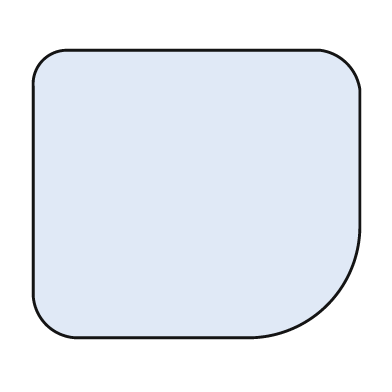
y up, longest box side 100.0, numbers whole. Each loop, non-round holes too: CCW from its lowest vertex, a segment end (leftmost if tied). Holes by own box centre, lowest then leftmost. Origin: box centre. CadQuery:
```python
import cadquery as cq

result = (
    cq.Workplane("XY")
    .moveTo(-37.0, -44.0)
    .lineTo(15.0, -44.0)
    .threePointArc((40.0, -34.0), (50.0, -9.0))
    .lineTo(50.0, 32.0)
    .threePointArc((46.0, 40.0), (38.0, 44.0))
    .lineTo(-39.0, 44.0)
    .threePointArc((-47.0, 41.0), (-50.0, 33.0))
    .lineTo(-50.0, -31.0)
    .threePointArc((-46.0, -40.0), (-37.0, -44.0))
    .close()
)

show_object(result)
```